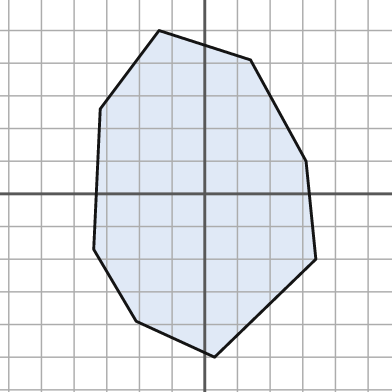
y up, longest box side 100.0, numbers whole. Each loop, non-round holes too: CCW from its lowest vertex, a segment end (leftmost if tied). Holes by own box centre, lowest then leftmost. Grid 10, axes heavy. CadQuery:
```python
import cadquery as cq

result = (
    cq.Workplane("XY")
    .moveTo(3.0, -50.0)
    .lineTo(34.0, -20.0)
    .lineTo(31.0, 10.0)
    .lineTo(14.0, 41.0)
    .lineTo(-14.0, 50.0)
    .lineTo(-32.0, 26.0)
    .lineTo(-34.0, -17.0)
    .lineTo(-21.0, -39.0)
    .close()
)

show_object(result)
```